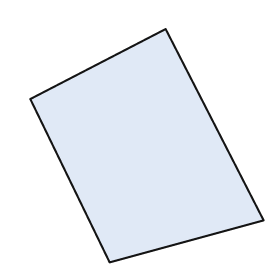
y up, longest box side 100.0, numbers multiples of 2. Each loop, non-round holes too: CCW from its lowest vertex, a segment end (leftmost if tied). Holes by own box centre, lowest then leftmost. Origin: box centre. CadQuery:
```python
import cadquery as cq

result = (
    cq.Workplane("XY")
    .moveTo(-16.0, -50.0)
    .lineTo(50.0, -32.0)
    .lineTo(8.0, 50.0)
    .lineTo(-50.0, 20.0)
    .close()
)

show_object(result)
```